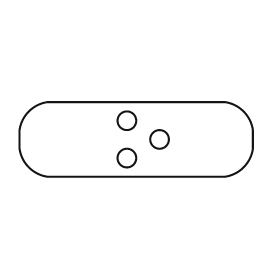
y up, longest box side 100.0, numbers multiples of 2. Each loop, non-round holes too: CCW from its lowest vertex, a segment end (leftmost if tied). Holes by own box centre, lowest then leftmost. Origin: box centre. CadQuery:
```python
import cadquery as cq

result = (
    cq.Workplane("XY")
    .moveTo(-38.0, -16.0)
    .lineTo(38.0, -16.0)
    .threePointArc((46.0, -12.0), (50.0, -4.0))
    .lineTo(50.0, 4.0)
    .threePointArc((46.0, 12.0), (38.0, 16.0))
    .lineTo(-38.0, 16.0)
    .threePointArc((-46.0, 12.0), (-50.0, 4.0))
    .lineTo(-50.0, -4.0)
    .threePointArc((-46.0, -12.0), (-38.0, -16.0))
    .close()
    .moveTo(-4.0, -8.0)
    .circle(4.0)
    .moveTo(10.0, 0.0)
    .circle(4.0)
    .moveTo(-4.0, 8.0)
    .circle(4.0)
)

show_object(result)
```